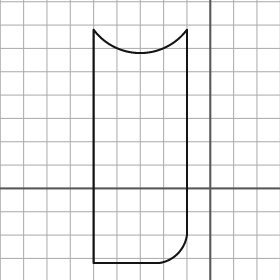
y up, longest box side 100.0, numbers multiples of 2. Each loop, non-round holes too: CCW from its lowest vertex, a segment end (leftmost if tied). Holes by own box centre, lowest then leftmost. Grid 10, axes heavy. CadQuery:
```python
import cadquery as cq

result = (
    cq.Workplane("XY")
    .moveTo(-50.0, -32.0)
    .lineTo(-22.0, -32.0)
    .threePointArc((-14.0, -28.0), (-10.0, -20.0))
    .lineTo(-10.0, 68.0)
    .threePointArc((-30.0, 58.0), (-50.0, 68.0))
    .close()
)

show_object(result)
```